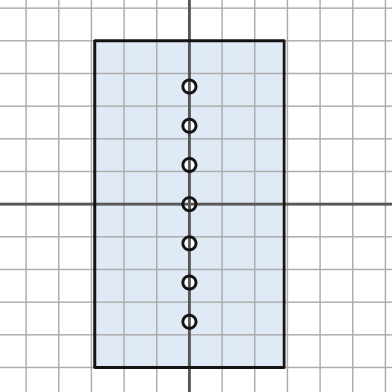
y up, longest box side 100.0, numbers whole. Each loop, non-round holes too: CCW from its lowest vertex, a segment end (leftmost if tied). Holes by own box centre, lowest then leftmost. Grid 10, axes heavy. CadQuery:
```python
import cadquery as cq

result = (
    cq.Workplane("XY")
    .moveTo(-29.0, -50.0)
    .lineTo(29.0, -50.0)
    .lineTo(29.0, 50.0)
    .lineTo(-29.0, 50.0)
    .close()
    .moveTo(0.0, -36.0)
    .circle(2.0)
    .moveTo(0.0, -24.0)
    .circle(2.0)
    .moveTo(0.0, -12.0)
    .circle(2.0)
    .moveTo(0.0, 0.0)
    .circle(2.0)
    .moveTo(0.0, 12.0)
    .circle(2.0)
    .moveTo(0.0, 24.0)
    .circle(2.0)
    .moveTo(0.0, 36.0)
    .circle(2.0)
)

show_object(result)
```